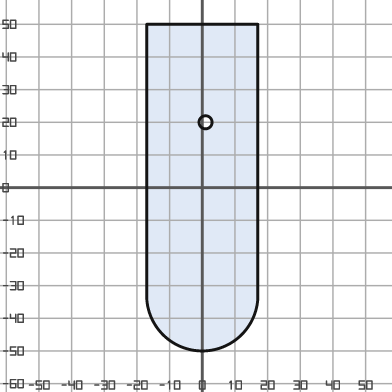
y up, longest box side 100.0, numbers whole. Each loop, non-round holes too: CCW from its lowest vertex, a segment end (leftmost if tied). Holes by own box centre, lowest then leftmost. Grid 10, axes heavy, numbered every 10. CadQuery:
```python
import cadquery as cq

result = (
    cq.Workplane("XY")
    .moveTo(-17.0, -34.0)
    .threePointArc((0.0, -50.0), (17.0, -34.0))
    .lineTo(17.0, 50.0)
    .lineTo(-17.0, 50.0)
    .close()
    .moveTo(1.0, 20.0)
    .circle(2.0)
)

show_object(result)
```